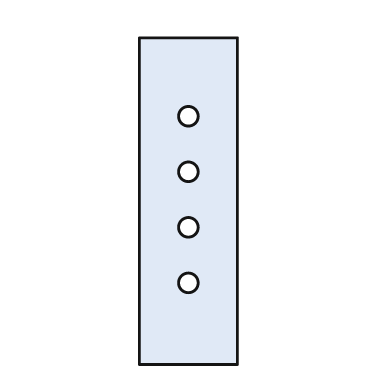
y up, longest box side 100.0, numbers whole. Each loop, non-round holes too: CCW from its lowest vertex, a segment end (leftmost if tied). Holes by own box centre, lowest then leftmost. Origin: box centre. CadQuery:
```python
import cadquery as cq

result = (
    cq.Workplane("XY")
    .moveTo(-15.0, -50.0)
    .lineTo(15.0, -50.0)
    .lineTo(15.0, 50.0)
    .lineTo(-15.0, 50.0)
    .close()
    .moveTo(0.0, -25.0)
    .circle(3.0)
    .moveTo(0.0, -8.0)
    .circle(3.0)
    .moveTo(0.0, 9.0)
    .circle(3.0)
    .moveTo(0.0, 26.0)
    .circle(3.0)
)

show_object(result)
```